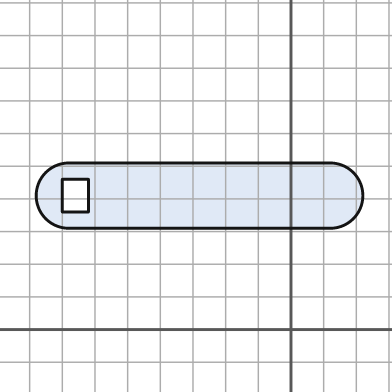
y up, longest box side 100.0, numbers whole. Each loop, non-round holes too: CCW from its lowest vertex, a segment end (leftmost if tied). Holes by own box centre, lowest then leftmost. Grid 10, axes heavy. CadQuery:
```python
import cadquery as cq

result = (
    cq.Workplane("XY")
    .moveTo(-68.0, 31.0)
    .lineTo(12.0, 31.0)
    .threePointArc((22.0, 41.0), (12.0, 51.0))
    .lineTo(-68.0, 51.0)
    .threePointArc((-78.0, 41.0), (-68.0, 31.0))
    .close()
    .moveTo(-70.0, 36.0)
    .lineTo(-62.0, 36.0)
    .lineTo(-62.0, 46.0)
    .lineTo(-70.0, 46.0)
    .close()
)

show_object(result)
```